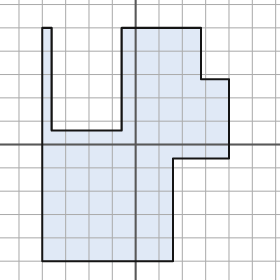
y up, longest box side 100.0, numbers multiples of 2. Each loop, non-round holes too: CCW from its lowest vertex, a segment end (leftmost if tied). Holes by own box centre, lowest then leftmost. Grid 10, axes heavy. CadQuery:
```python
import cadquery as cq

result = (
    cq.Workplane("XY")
    .moveTo(-40.0, -50.0)
    .lineTo(16.0, -50.0)
    .lineTo(16.0, -6.0)
    .lineTo(40.0, -6.0)
    .lineTo(40.0, 28.0)
    .lineTo(28.0, 28.0)
    .lineTo(28.0, 50.0)
    .lineTo(-6.0, 50.0)
    .lineTo(-6.0, 6.0)
    .lineTo(-36.0, 6.0)
    .lineTo(-36.0, 50.0)
    .lineTo(-40.0, 50.0)
    .close()
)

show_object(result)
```